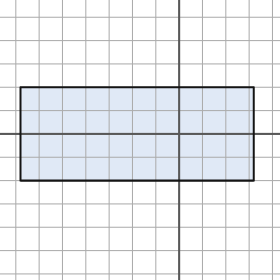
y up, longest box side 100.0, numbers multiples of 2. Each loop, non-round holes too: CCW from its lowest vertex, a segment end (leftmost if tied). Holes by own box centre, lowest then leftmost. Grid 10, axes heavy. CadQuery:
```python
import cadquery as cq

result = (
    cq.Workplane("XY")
    .moveTo(-68.0, -20.0)
    .lineTo(32.0, -20.0)
    .lineTo(32.0, 20.0)
    .lineTo(-68.0, 20.0)
    .close()
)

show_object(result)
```